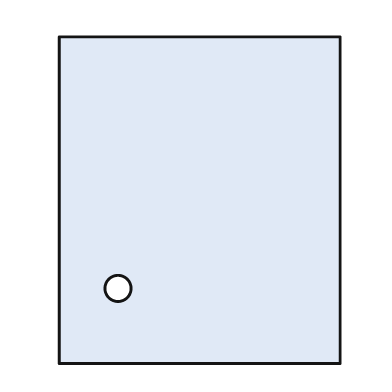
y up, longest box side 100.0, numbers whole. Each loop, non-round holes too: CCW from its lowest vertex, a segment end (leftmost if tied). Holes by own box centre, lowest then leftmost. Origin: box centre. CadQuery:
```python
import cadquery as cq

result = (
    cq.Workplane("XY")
    .moveTo(-43.0, -50.0)
    .lineTo(43.0, -50.0)
    .lineTo(43.0, 50.0)
    .lineTo(-43.0, 50.0)
    .close()
    .moveTo(-25.0, -27.0)
    .circle(4.0)
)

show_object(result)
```